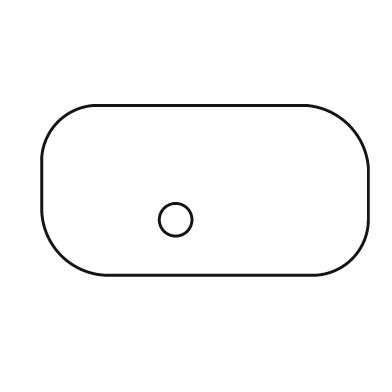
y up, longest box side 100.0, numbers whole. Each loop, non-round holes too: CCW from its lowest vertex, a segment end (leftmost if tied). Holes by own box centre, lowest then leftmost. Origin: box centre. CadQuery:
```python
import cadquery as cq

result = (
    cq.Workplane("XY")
    .moveTo(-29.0, -26.0)
    .lineTo(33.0, -26.0)
    .threePointArc((45.0, -21.0), (50.0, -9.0))
    .lineTo(50.0, 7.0)
    .threePointArc((44.0, 20.0), (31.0, 26.0))
    .lineTo(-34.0, 26.0)
    .threePointArc((-45.0, 21.0), (-50.0, 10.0))
    .lineTo(-50.0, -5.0)
    .threePointArc((-44.0, -20.0), (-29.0, -26.0))
    .close()
    .moveTo(-9.0, -9.0)
    .circle(5.0)
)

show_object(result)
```